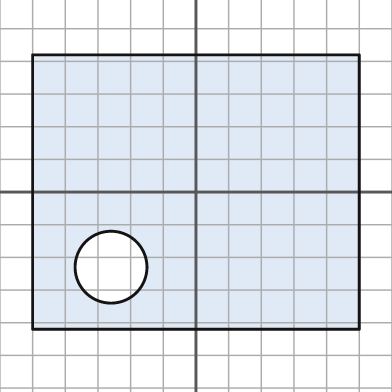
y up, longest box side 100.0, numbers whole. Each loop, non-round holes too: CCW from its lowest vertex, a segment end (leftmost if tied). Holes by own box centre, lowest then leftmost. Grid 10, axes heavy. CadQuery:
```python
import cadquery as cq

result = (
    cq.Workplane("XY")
    .moveTo(-50.0, -42.0)
    .lineTo(50.0, -42.0)
    .lineTo(50.0, 42.0)
    .lineTo(-50.0, 42.0)
    .close()
    .moveTo(-26.0, -23.0)
    .circle(11.0)
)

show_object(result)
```